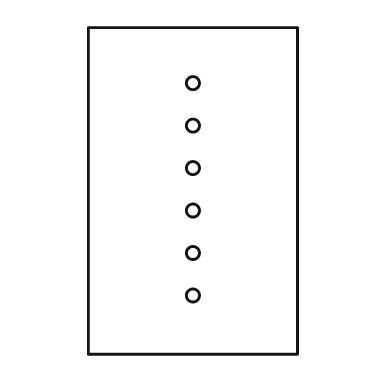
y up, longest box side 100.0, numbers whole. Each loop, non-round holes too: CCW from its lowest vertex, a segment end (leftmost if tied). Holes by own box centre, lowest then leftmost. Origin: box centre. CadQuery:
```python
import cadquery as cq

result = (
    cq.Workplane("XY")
    .moveTo(-32.0, -50.0)
    .lineTo(32.0, -50.0)
    .lineTo(32.0, 50.0)
    .lineTo(-32.0, 50.0)
    .close()
    .moveTo(0.0, -32.0)
    .circle(2.0)
    .moveTo(0.0, -19.0)
    .circle(2.0)
    .moveTo(0.0, -6.0)
    .circle(2.0)
    .moveTo(0.0, 7.0)
    .circle(2.0)
    .moveTo(0.0, 20.0)
    .circle(2.0)
    .moveTo(0.0, 33.0)
    .circle(2.0)
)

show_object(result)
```